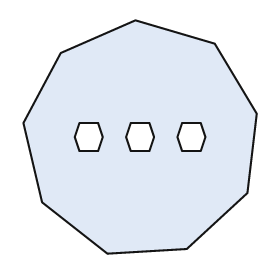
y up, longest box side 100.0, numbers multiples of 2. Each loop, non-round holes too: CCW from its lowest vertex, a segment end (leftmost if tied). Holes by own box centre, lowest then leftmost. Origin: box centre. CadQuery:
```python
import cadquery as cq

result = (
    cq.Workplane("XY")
    .moveTo(-14.0, -50.0)
    .lineTo(20.0, -48.0)
    .lineTo(46.0, -24.0)
    .lineTo(50.0, 10.0)
    .lineTo(32.0, 40.0)
    .lineTo(-2.0, 50.0)
    .lineTo(-34.0, 36.0)
    .lineTo(-50.0, 6.0)
    .lineTo(-42.0, -28.0)
    .close()
    .moveTo(-26.0, -6.0)
    .lineTo(-18.0, -6.0)
    .lineTo(-16.0, 0.0)
    .lineTo(-18.0, 6.0)
    .lineTo(-26.0, 6.0)
    .lineTo(-28.0, 0.0)
    .close()
    .moveTo(-4.0, -6.0)
    .lineTo(4.0, -6.0)
    .lineTo(6.0, 0.0)
    .lineTo(4.0, 6.0)
    .lineTo(-4.0, 6.0)
    .lineTo(-6.0, 0.0)
    .close()
    .moveTo(18.0, -6.0)
    .lineTo(26.0, -6.0)
    .lineTo(28.0, 0.0)
    .lineTo(26.0, 6.0)
    .lineTo(18.0, 6.0)
    .lineTo(16.0, 0.0)
    .close()
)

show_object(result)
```